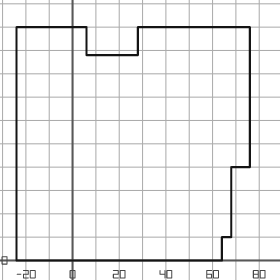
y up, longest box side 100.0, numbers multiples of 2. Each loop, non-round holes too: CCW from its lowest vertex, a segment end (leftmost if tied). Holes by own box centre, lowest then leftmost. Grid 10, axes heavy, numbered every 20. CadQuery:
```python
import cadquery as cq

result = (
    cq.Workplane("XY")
    .moveTo(-24.0, 0.0)
    .lineTo(64.0, 0.0)
    .lineTo(64.0, 10.0)
    .lineTo(68.0, 10.0)
    .lineTo(68.0, 40.0)
    .lineTo(76.0, 40.0)
    .lineTo(76.0, 100.0)
    .lineTo(28.0, 100.0)
    .lineTo(28.0, 88.0)
    .lineTo(6.0, 88.0)
    .lineTo(6.0, 100.0)
    .lineTo(-24.0, 100.0)
    .close()
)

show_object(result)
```